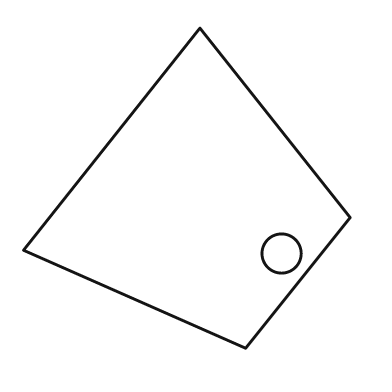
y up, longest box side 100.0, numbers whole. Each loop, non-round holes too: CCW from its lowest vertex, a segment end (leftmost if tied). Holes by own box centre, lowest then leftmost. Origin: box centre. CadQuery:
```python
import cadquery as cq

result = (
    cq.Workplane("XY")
    .moveTo(18.0, -49.0)
    .lineTo(50.0, -9.0)
    .lineTo(4.0, 49.0)
    .lineTo(-50.0, -19.0)
    .close()
    .moveTo(29.0, -20.0)
    .circle(6.0)
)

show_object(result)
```